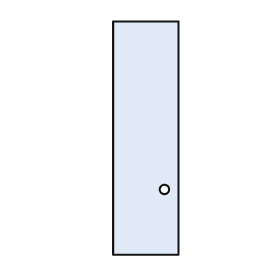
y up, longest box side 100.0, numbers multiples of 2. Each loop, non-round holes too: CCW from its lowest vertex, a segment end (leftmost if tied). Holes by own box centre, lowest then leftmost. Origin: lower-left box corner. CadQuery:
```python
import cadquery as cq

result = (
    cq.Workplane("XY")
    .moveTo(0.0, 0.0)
    .lineTo(28.0, 0.0)
    .lineTo(28.0, 100.0)
    .lineTo(0.0, 100.0)
    .close()
    .moveTo(22.0, 28.0)
    .circle(2.0)
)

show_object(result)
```